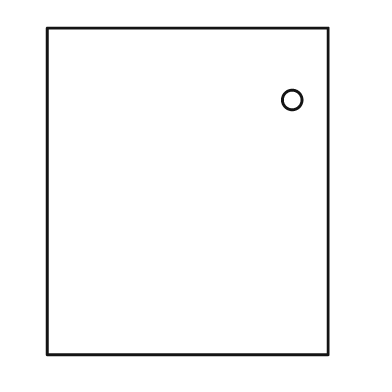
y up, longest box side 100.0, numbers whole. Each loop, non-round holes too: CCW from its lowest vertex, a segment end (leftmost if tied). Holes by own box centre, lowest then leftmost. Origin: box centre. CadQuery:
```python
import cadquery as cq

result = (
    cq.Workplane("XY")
    .moveTo(-43.0, -50.0)
    .lineTo(43.0, -50.0)
    .lineTo(43.0, 50.0)
    .lineTo(-43.0, 50.0)
    .close()
    .moveTo(32.0, 28.0)
    .circle(3.0)
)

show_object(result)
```